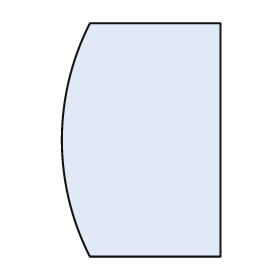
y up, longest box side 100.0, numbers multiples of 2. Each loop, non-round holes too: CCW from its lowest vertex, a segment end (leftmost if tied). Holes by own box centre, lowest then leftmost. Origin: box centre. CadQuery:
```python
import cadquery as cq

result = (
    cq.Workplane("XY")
    .moveTo(-22.0, -50.0)
    .lineTo(34.0, -50.0)
    .lineTo(34.0, 50.0)
    .lineTo(-22.0, 50.0)
    .threePointArc((-34.0, 0.0), (-22.0, -50.0))
    .close()
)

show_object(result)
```